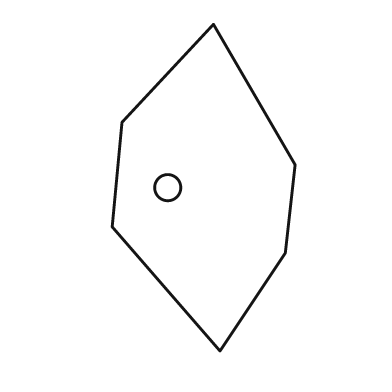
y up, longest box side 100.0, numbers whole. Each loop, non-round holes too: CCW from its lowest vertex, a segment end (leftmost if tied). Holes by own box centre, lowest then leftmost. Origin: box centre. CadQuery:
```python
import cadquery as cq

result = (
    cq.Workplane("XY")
    .moveTo(5.0, -50.0)
    .lineTo(25.0, -20.0)
    .lineTo(28.0, 7.0)
    .lineTo(3.0, 50.0)
    .lineTo(-25.0, 20.0)
    .lineTo(-28.0, -12.0)
    .close()
    .moveTo(-11.0, 0.0)
    .circle(4.0)
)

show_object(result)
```